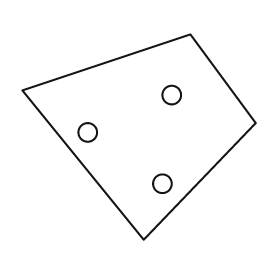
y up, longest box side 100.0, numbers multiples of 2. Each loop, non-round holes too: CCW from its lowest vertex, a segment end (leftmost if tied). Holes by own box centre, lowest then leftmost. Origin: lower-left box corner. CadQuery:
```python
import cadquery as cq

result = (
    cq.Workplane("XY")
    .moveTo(52.0, 0.0)
    .lineTo(100.0, 50.0)
    .lineTo(72.0, 88.0)
    .lineTo(0.0, 64.0)
    .close()
    .moveTo(60.0, 24.0)
    .circle(4.0)
    .moveTo(28.0, 46.0)
    .circle(4.0)
    .moveTo(64.0, 62.0)
    .circle(4.0)
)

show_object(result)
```